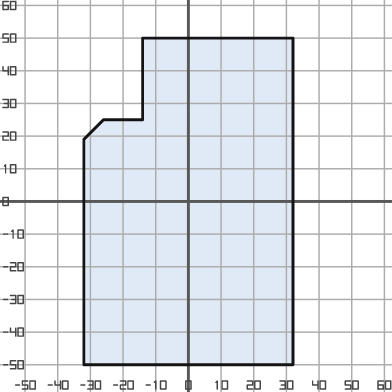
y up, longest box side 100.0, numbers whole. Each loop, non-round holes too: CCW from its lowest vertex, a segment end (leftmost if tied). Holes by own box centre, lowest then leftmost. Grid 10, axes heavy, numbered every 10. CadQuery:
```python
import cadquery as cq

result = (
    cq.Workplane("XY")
    .moveTo(-32.0, -50.0)
    .lineTo(32.0, -50.0)
    .lineTo(32.0, 50.0)
    .lineTo(-14.0, 50.0)
    .lineTo(-14.0, 25.0)
    .lineTo(-26.0, 25.0)
    .lineTo(-32.0, 19.0)
    .close()
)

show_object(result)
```